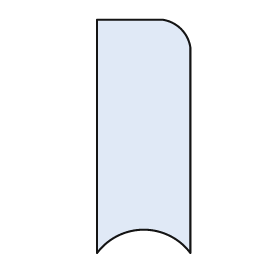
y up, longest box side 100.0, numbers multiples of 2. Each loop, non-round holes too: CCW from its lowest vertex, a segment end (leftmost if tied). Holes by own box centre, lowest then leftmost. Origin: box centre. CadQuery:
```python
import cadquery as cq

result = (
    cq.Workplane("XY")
    .moveTo(-20.0, -50.0)
    .threePointArc((0.0, -40.0), (20.0, -50.0))
    .lineTo(20.0, 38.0)
    .threePointArc((16.0, 46.0), (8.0, 50.0))
    .lineTo(-20.0, 50.0)
    .close()
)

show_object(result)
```